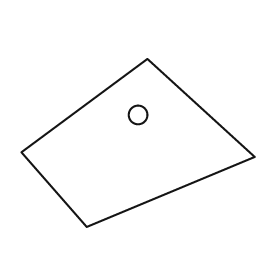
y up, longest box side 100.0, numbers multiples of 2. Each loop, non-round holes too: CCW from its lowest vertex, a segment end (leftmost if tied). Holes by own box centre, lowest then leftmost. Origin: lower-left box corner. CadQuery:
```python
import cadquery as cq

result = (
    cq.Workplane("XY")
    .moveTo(28.0, 0.0)
    .lineTo(100.0, 30.0)
    .lineTo(54.0, 72.0)
    .lineTo(0.0, 32.0)
    .close()
    .moveTo(50.0, 48.0)
    .circle(4.0)
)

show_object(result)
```